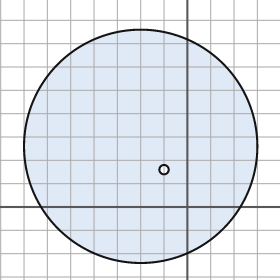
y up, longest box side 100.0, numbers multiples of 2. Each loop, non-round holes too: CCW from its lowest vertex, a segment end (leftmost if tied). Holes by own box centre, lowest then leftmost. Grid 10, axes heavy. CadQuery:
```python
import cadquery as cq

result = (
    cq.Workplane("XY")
    .moveTo(-20.0, 26.0)
    .circle(50.0)
    .moveTo(-10.0, 16.0)
    .circle(2.0)
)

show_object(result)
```